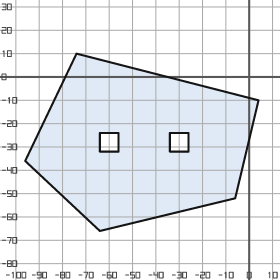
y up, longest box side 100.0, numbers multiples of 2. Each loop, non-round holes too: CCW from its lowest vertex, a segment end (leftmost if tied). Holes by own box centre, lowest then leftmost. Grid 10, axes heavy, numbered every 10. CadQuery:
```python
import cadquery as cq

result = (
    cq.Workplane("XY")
    .moveTo(-64.0, -66.0)
    .lineTo(-6.0, -52.0)
    .lineTo(4.0, -10.0)
    .lineTo(-74.0, 10.0)
    .lineTo(-96.0, -36.0)
    .close()
    .moveTo(-64.0, -32.0)
    .lineTo(-56.0, -32.0)
    .lineTo(-56.0, -24.0)
    .lineTo(-64.0, -24.0)
    .close()
    .moveTo(-34.0, -32.0)
    .lineTo(-26.0, -32.0)
    .lineTo(-26.0, -24.0)
    .lineTo(-34.0, -24.0)
    .close()
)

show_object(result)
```